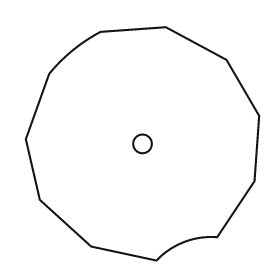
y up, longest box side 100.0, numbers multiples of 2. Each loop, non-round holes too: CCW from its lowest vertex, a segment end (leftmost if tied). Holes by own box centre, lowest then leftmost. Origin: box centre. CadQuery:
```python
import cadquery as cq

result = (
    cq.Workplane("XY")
    .moveTo(6.0, -50.0)
    .threePointArc((18.0, -42.0), (32.0, -40.0))
    .lineTo(48.0, -16.0)
    .lineTo(50.0, 12.0)
    .lineTo(36.0, 36.0)
    .lineTo(10.0, 50.0)
    .lineTo(-18.0, 48.0)
    .threePointArc((-30.0, 40.0), (-40.0, 30.0))
    .lineTo(-50.0, 2.0)
    .lineTo(-44.0, -24.0)
    .lineTo(-22.0, -44.0)
    .close()
    .moveTo(0.0, 0.0)
    .circle(4.0)
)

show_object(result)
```